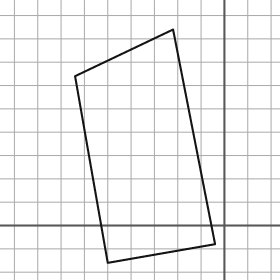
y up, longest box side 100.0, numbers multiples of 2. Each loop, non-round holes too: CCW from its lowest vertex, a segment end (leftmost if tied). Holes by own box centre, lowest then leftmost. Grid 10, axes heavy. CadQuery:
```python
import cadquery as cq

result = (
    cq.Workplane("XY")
    .moveTo(-50.0, -16.0)
    .lineTo(-4.0, -8.0)
    .lineTo(-22.0, 84.0)
    .lineTo(-64.0, 64.0)
    .close()
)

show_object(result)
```